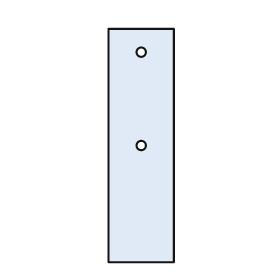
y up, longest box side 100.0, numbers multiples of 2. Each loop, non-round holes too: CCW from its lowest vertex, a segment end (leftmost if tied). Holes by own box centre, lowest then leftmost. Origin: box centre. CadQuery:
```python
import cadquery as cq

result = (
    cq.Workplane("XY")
    .moveTo(-14.0, -50.0)
    .lineTo(14.0, -50.0)
    .lineTo(14.0, 50.0)
    .lineTo(-14.0, 50.0)
    .close()
    .moveTo(0.0, 0.0)
    .circle(2.0)
    .moveTo(0.0, 40.0)
    .circle(2.0)
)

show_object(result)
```